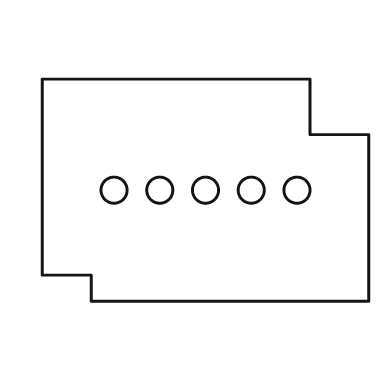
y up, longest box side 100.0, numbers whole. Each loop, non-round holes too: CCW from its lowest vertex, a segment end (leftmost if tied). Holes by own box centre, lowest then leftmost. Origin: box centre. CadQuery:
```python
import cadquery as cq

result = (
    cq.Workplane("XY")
    .moveTo(-35.0, -34.0)
    .lineTo(50.0, -34.0)
    .lineTo(50.0, 17.0)
    .lineTo(32.0, 17.0)
    .lineTo(32.0, 34.0)
    .lineTo(-50.0, 34.0)
    .lineTo(-50.0, -26.0)
    .lineTo(-35.0, -26.0)
    .close()
    .moveTo(-28.0, 0.0)
    .circle(4.0)
    .moveTo(-14.0, 0.0)
    .circle(4.0)
    .moveTo(0.0, 0.0)
    .circle(4.0)
    .moveTo(14.0, 0.0)
    .circle(4.0)
    .moveTo(28.0, 0.0)
    .circle(4.0)
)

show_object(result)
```